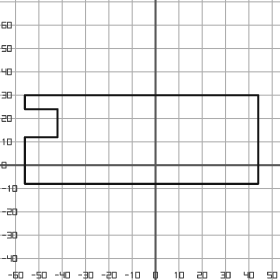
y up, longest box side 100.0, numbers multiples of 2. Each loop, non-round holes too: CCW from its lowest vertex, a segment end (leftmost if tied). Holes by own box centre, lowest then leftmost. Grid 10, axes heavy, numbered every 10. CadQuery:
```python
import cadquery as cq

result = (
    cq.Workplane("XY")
    .moveTo(-56.0, -8.0)
    .lineTo(44.0, -8.0)
    .lineTo(44.0, 30.0)
    .lineTo(-56.0, 30.0)
    .lineTo(-56.0, 24.0)
    .lineTo(-42.0, 24.0)
    .lineTo(-42.0, 12.0)
    .lineTo(-56.0, 12.0)
    .close()
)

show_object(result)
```